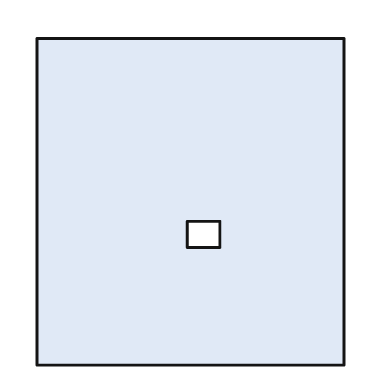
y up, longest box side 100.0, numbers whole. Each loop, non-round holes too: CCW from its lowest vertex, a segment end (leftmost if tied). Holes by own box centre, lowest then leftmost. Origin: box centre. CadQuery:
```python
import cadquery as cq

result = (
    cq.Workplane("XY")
    .moveTo(-47.0, -50.0)
    .lineTo(47.0, -50.0)
    .lineTo(47.0, 50.0)
    .lineTo(-47.0, 50.0)
    .close()
    .moveTo(-1.0, -14.0)
    .lineTo(9.0, -14.0)
    .lineTo(9.0, -6.0)
    .lineTo(-1.0, -6.0)
    .close()
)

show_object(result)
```